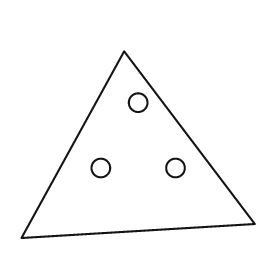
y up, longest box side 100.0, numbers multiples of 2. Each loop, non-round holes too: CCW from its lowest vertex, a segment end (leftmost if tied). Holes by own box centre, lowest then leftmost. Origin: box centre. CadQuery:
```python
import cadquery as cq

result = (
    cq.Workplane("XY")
    .moveTo(-50.0, -40.0)
    .lineTo(50.0, -34.0)
    .lineTo(-6.0, 40.0)
    .close()
    .moveTo(-16.0, -10.0)
    .circle(4.0)
    .moveTo(16.0, -10.0)
    .circle(4.0)
    .moveTo(0.0, 18.0)
    .circle(4.0)
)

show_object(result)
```